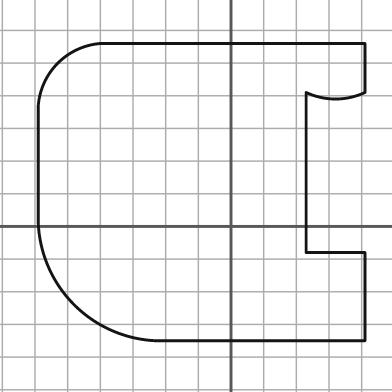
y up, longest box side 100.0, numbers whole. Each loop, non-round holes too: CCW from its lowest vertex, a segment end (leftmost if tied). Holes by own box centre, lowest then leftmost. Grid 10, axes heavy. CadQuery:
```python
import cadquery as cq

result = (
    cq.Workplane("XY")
    .moveTo(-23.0, -35.0)
    .lineTo(41.0, -35.0)
    .lineTo(41.0, -8.0)
    .lineTo(23.0, -8.0)
    .lineTo(23.0, 41.0)
    .threePointArc((32.0, 39.0), (41.0, 41.0))
    .lineTo(41.0, 56.0)
    .lineTo(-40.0, 56.0)
    .threePointArc((-53.0, 50.0), (-59.0, 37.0))
    .lineTo(-59.0, 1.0)
    .threePointArc((-48.0, -24.0), (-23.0, -35.0))
    .close()
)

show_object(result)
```